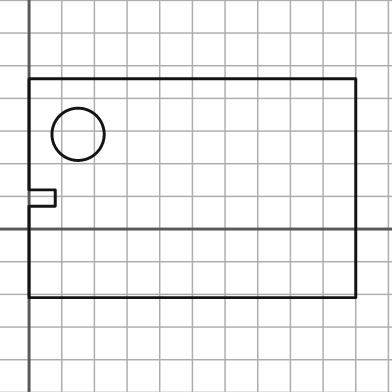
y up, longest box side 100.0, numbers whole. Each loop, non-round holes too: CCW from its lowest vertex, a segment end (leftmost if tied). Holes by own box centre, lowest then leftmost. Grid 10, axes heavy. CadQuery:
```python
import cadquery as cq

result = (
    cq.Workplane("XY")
    .moveTo(0.0, -21.0)
    .lineTo(100.0, -21.0)
    .lineTo(100.0, 46.0)
    .lineTo(0.0, 46.0)
    .lineTo(0.0, 12.0)
    .lineTo(8.0, 12.0)
    .lineTo(8.0, 7.0)
    .lineTo(0.0, 7.0)
    .close()
    .moveTo(15.0, 29.0)
    .circle(8.0)
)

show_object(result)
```